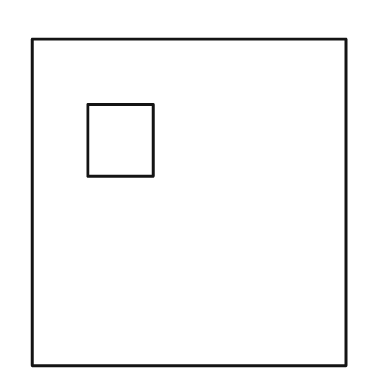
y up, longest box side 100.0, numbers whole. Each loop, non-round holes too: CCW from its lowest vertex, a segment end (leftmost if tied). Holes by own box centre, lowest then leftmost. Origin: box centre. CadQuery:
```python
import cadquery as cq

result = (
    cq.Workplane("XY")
    .moveTo(-48.0, -50.0)
    .lineTo(48.0, -50.0)
    .lineTo(48.0, 50.0)
    .lineTo(-48.0, 50.0)
    .close()
    .moveTo(-31.0, 8.0)
    .lineTo(-11.0, 8.0)
    .lineTo(-11.0, 30.0)
    .lineTo(-31.0, 30.0)
    .close()
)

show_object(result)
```